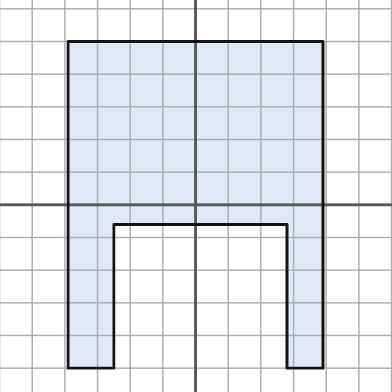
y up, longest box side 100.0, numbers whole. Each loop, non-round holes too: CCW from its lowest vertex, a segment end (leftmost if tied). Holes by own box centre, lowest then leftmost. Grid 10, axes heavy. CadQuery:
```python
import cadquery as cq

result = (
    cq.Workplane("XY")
    .moveTo(-39.0, -50.0)
    .lineTo(-25.0, -50.0)
    .lineTo(-25.0, -6.0)
    .lineTo(28.0, -6.0)
    .lineTo(28.0, -50.0)
    .lineTo(39.0, -50.0)
    .lineTo(39.0, 50.0)
    .lineTo(-39.0, 50.0)
    .close()
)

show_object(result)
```